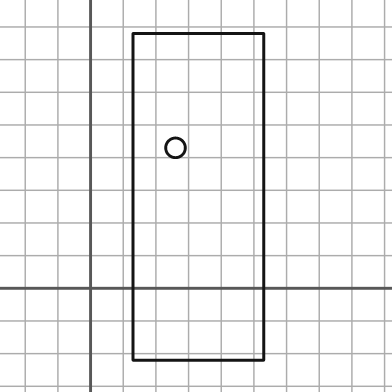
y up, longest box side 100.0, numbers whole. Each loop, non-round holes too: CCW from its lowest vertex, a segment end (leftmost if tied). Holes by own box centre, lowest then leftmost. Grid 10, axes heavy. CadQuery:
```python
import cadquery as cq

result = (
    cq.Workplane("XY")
    .moveTo(13.0, -22.0)
    .lineTo(53.0, -22.0)
    .lineTo(53.0, 78.0)
    .lineTo(13.0, 78.0)
    .close()
    .moveTo(26.0, 43.0)
    .circle(3.0)
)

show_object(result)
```